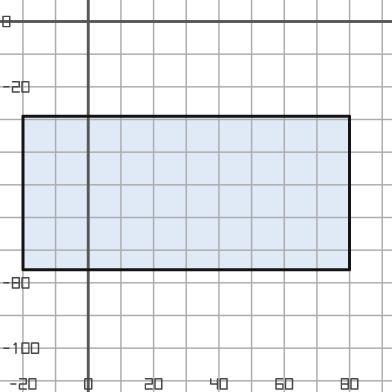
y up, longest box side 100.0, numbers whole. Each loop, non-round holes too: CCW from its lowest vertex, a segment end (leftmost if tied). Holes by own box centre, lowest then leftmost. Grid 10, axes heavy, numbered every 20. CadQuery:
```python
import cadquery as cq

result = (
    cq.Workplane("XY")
    .moveTo(-20.0, -76.0)
    .lineTo(80.0, -76.0)
    .lineTo(80.0, -29.0)
    .lineTo(-20.0, -29.0)
    .close()
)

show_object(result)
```